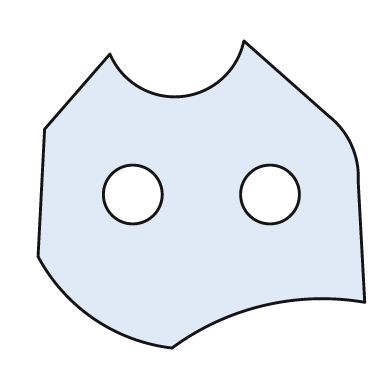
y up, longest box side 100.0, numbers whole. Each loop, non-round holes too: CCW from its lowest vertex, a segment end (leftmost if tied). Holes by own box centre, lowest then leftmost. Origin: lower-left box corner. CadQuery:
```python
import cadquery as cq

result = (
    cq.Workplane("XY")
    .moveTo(41.0, 0.0)
    .threePointArc((69.0, 13.0), (100.0, 14.0))
    .lineTo(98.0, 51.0)
    .threePointArc((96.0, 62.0), (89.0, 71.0))
    .lineTo(63.0, 94.0)
    .threePointArc((44.0, 77.0), (22.0, 90.0))
    .lineTo(2.0, 67.0)
    .lineTo(0.0, 28.0)
    .threePointArc((17.0, 9.0), (41.0, 0.0))
    .close()
    .moveTo(29.0, 47.0)
    .circle(9.0)
    .moveTo(71.0, 47.0)
    .circle(9.0)
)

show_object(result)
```